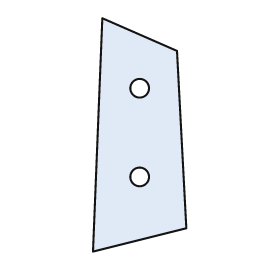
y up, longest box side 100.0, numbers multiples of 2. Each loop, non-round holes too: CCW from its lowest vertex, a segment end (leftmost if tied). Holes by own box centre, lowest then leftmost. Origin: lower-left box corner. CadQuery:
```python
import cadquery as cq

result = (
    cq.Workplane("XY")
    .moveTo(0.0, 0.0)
    .lineTo(40.0, 10.0)
    .lineTo(36.0, 86.0)
    .lineTo(4.0, 100.0)
    .close()
    .moveTo(20.0, 32.0)
    .circle(4.0)
    .moveTo(20.0, 70.0)
    .circle(4.0)
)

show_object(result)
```